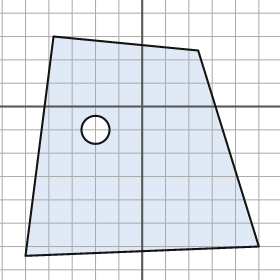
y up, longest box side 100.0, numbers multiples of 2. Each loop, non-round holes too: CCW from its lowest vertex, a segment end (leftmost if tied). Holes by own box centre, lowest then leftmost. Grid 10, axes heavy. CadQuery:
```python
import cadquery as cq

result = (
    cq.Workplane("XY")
    .moveTo(-50.0, -64.0)
    .lineTo(50.0, -60.0)
    .lineTo(24.0, 24.0)
    .lineTo(-38.0, 30.0)
    .close()
    .moveTo(-20.0, -10.0)
    .circle(6.0)
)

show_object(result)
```